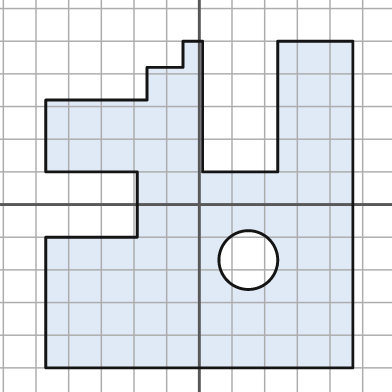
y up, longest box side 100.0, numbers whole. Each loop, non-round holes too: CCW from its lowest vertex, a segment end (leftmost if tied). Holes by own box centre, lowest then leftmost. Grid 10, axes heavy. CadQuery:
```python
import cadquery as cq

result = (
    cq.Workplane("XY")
    .moveTo(-47.0, -50.0)
    .lineTo(47.0, -50.0)
    .lineTo(47.0, 50.0)
    .lineTo(24.0, 50.0)
    .lineTo(24.0, 10.0)
    .lineTo(1.0, 10.0)
    .lineTo(1.0, 50.0)
    .lineTo(-5.0, 50.0)
    .lineTo(-5.0, 42.0)
    .lineTo(-16.0, 42.0)
    .lineTo(-16.0, 32.0)
    .lineTo(-47.0, 32.0)
    .lineTo(-47.0, 10.0)
    .lineTo(-19.0, 10.0)
    .lineTo(-19.0, -10.0)
    .lineTo(-47.0, -10.0)
    .close()
    .moveTo(15.0, -17.0)
    .circle(9.0)
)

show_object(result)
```